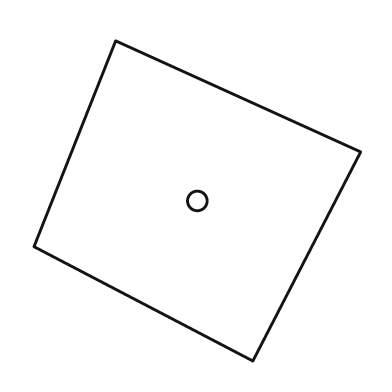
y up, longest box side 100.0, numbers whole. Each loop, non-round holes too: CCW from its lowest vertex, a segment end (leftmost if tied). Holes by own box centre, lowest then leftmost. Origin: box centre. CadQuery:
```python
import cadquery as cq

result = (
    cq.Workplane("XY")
    .moveTo(17.0, -49.0)
    .lineTo(50.0, 15.0)
    .lineTo(-25.0, 49.0)
    .lineTo(-50.0, -14.0)
    .close()
    .moveTo(0.0, 0.0)
    .circle(3.0)
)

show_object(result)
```